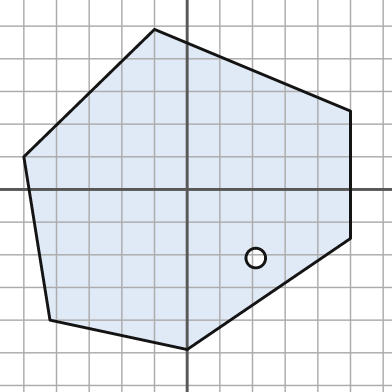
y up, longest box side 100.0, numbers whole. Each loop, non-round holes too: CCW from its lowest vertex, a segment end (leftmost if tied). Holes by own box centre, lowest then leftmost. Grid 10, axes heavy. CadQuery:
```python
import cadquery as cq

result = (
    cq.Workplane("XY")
    .moveTo(0.0, -49.0)
    .lineTo(50.0, -15.0)
    .lineTo(50.0, 24.0)
    .lineTo(-10.0, 49.0)
    .lineTo(-50.0, 10.0)
    .lineTo(-42.0, -40.0)
    .close()
    .moveTo(21.0, -21.0)
    .circle(3.0)
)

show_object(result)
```